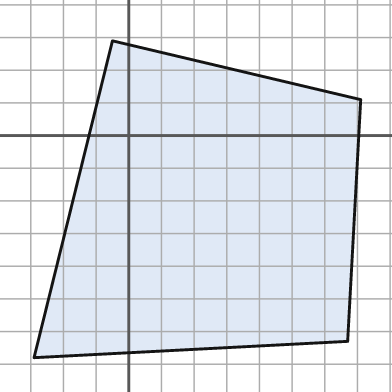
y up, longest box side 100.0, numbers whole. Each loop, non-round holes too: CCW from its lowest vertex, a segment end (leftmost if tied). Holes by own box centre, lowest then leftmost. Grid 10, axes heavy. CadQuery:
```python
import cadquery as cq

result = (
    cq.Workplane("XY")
    .moveTo(-29.0, -68.0)
    .lineTo(67.0, -63.0)
    .lineTo(71.0, 11.0)
    .lineTo(-5.0, 29.0)
    .close()
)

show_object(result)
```